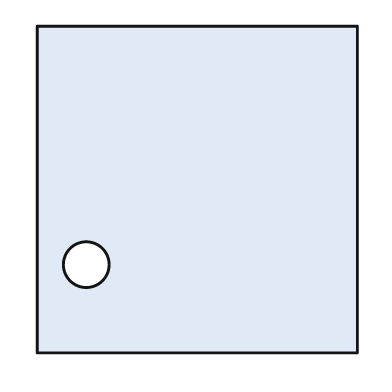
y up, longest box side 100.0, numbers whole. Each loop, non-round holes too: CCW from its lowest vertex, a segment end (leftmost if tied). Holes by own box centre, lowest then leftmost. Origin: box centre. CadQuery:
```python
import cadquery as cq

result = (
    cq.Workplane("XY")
    .moveTo(-49.0, -50.0)
    .lineTo(49.0, -50.0)
    .lineTo(49.0, 50.0)
    .lineTo(-49.0, 50.0)
    .close()
    .moveTo(-34.0, -23.0)
    .circle(7.0)
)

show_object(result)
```